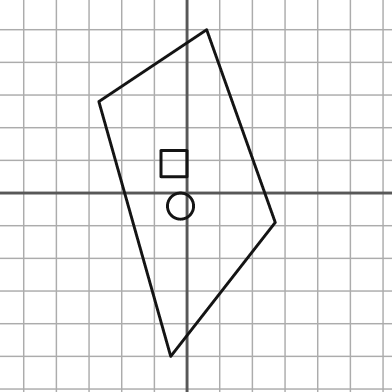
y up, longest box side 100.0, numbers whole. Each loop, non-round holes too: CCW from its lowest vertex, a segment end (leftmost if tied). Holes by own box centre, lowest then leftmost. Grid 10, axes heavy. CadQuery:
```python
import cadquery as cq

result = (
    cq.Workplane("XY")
    .moveTo(-5.0, -50.0)
    .lineTo(27.0, -9.0)
    .lineTo(6.0, 50.0)
    .lineTo(-27.0, 28.0)
    .close()
    .moveTo(-2.0, -4.0)
    .circle(4.0)
    .moveTo(-8.0, 5.0)
    .lineTo(0.0, 5.0)
    .lineTo(0.0, 13.0)
    .lineTo(-8.0, 13.0)
    .close()
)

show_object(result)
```